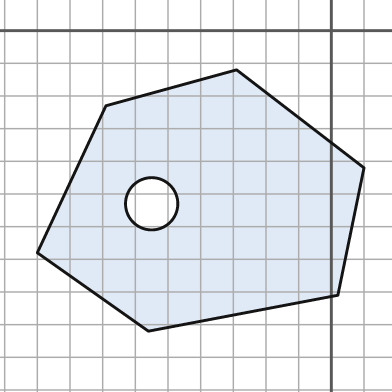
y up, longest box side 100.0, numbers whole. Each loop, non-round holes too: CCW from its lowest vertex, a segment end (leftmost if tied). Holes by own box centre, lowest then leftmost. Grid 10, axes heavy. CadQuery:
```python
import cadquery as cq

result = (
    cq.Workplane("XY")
    .moveTo(-56.0, -92.0)
    .lineTo(2.0, -81.0)
    .lineTo(10.0, -42.0)
    .lineTo(-29.0, -12.0)
    .lineTo(-69.0, -23.0)
    .lineTo(-90.0, -68.0)
    .close()
    .moveTo(-55.0, -53.0)
    .circle(8.0)
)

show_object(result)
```